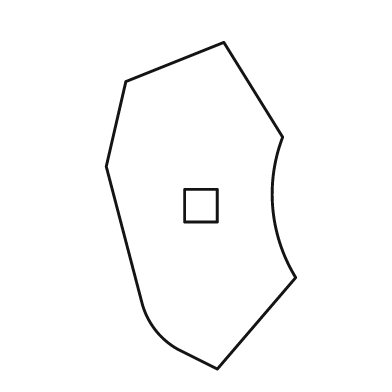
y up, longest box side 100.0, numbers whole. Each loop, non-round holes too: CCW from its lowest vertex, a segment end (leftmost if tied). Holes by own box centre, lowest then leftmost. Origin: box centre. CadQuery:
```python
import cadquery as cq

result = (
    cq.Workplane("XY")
    .moveTo(5.0, -50.0)
    .lineTo(29.0, -22.0)
    .threePointArc((22.0, -1.0), (25.0, 21.0))
    .lineTo(7.0, 50.0)
    .lineTo(-23.0, 38.0)
    .lineTo(-29.0, 12.0)
    .lineTo(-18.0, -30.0)
    .threePointArc((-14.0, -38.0), (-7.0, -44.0))
    .close()
    .moveTo(-5.0, -5.0)
    .lineTo(5.0, -5.0)
    .lineTo(5.0, 5.0)
    .lineTo(-5.0, 5.0)
    .close()
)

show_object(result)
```